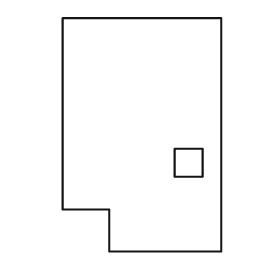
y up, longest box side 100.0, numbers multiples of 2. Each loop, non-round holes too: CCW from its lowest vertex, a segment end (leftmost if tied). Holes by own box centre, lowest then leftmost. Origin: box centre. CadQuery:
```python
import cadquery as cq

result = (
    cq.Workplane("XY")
    .moveTo(-14.0, -50.0)
    .lineTo(34.0, -50.0)
    .lineTo(34.0, 50.0)
    .lineTo(-34.0, 50.0)
    .lineTo(-34.0, -32.0)
    .lineTo(-14.0, -32.0)
    .close()
    .moveTo(14.0, -18.0)
    .lineTo(26.0, -18.0)
    .lineTo(26.0, -6.0)
    .lineTo(14.0, -6.0)
    .close()
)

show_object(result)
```